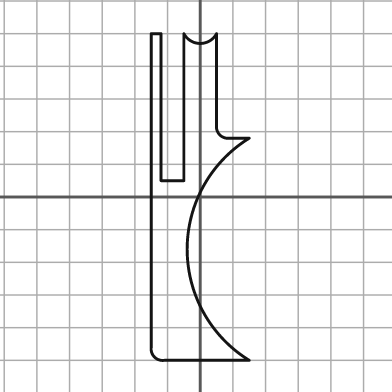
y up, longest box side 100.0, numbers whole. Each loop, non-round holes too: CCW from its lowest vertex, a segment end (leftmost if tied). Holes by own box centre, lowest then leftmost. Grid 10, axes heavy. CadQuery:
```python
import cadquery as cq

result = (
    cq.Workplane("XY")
    .moveTo(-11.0, -50.0)
    .lineTo(15.0, -50.0)
    .threePointArc((-4.0, -16.0), (15.0, 18.0))
    .lineTo(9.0, 18.0)
    .threePointArc((6.0, 19.0), (5.0, 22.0))
    .lineTo(5.0, 50.0)
    .threePointArc((0.0, 47.0), (-5.0, 50.0))
    .lineTo(-5.0, 5.0)
    .lineTo(-12.0, 5.0)
    .lineTo(-12.0, 50.0)
    .lineTo(-15.0, 50.0)
    .lineTo(-15.0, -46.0)
    .threePointArc((-14.0, -49.0), (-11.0, -50.0))
    .close()
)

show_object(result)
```